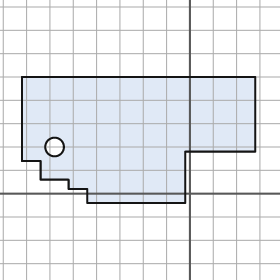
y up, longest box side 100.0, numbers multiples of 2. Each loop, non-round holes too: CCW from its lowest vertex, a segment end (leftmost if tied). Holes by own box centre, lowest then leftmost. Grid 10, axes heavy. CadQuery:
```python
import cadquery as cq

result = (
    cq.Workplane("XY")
    .moveTo(-44.0, -4.0)
    .lineTo(-2.0, -4.0)
    .lineTo(-2.0, 18.0)
    .lineTo(28.0, 18.0)
    .lineTo(28.0, 50.0)
    .lineTo(-72.0, 50.0)
    .lineTo(-72.0, 14.0)
    .lineTo(-64.0, 14.0)
    .lineTo(-64.0, 6.0)
    .lineTo(-52.0, 6.0)
    .lineTo(-52.0, 2.0)
    .lineTo(-44.0, 2.0)
    .close()
    .moveTo(-58.0, 20.0)
    .circle(4.0)
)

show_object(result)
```